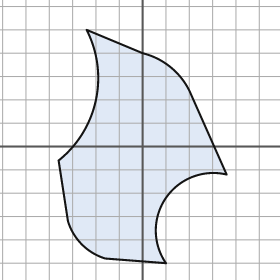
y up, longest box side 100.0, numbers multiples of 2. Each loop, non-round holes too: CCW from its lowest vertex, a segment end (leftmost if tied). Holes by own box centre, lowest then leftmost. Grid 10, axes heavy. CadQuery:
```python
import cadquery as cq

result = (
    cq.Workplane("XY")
    .moveTo(10.0, -50.0)
    .threePointArc((10.0, -22.0), (36.0, -12.0))
    .lineTo(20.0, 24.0)
    .threePointArc((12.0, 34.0), (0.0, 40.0))
    .lineTo(-24.0, 50.0)
    .threePointArc((-20.0, 20.0), (-36.0, -6.0))
    .lineTo(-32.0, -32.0)
    .threePointArc((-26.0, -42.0), (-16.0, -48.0))
    .close()
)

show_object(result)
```